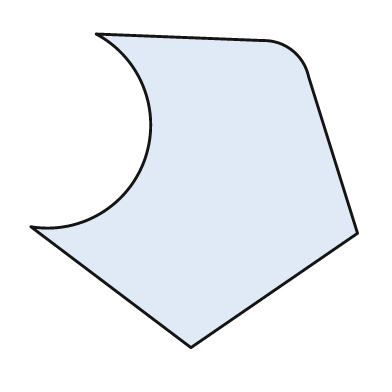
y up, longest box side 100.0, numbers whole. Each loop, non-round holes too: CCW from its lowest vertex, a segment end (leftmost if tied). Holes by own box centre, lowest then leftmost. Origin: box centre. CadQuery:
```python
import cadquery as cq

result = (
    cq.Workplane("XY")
    .moveTo(-1.0, -48.0)
    .lineTo(50.0, -13.0)
    .lineTo(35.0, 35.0)
    .threePointArc((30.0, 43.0), (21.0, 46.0))
    .lineTo(-30.0, 48.0)
    .threePointArc((-15.0, 10.0), (-50.0, -11.0))
    .close()
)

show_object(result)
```